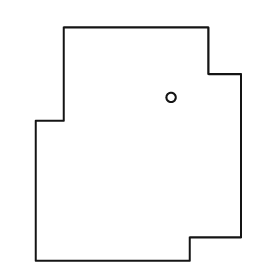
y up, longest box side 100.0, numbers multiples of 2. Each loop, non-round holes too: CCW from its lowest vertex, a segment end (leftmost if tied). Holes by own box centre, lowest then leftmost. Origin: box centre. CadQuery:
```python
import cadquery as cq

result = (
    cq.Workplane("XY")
    .moveTo(-44.0, -50.0)
    .lineTo(22.0, -50.0)
    .lineTo(22.0, -40.0)
    .lineTo(44.0, -40.0)
    .lineTo(44.0, 30.0)
    .lineTo(30.0, 30.0)
    .lineTo(30.0, 50.0)
    .lineTo(-32.0, 50.0)
    .lineTo(-32.0, 10.0)
    .lineTo(-44.0, 10.0)
    .close()
    .moveTo(14.0, 20.0)
    .circle(2.0)
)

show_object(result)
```